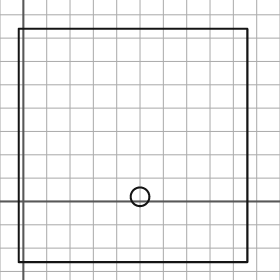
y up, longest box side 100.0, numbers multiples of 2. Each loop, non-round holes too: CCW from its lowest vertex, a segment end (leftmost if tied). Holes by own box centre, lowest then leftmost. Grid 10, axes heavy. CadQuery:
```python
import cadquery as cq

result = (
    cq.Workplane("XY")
    .moveTo(-2.0, -26.0)
    .lineTo(96.0, -26.0)
    .lineTo(96.0, 74.0)
    .lineTo(-2.0, 74.0)
    .close()
    .moveTo(50.0, 2.0)
    .circle(4.0)
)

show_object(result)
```